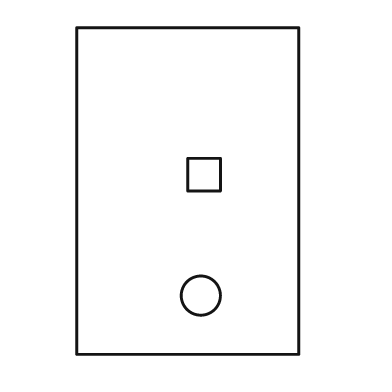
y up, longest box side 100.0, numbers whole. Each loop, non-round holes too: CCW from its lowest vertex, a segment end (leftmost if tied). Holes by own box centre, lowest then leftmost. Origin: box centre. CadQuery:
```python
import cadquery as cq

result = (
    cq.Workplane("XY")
    .moveTo(-34.0, -50.0)
    .lineTo(34.0, -50.0)
    .lineTo(34.0, 50.0)
    .lineTo(-34.0, 50.0)
    .close()
    .moveTo(4.0, -32.0)
    .circle(6.0)
    .moveTo(0.0, 0.0)
    .lineTo(10.0, 0.0)
    .lineTo(10.0, 10.0)
    .lineTo(0.0, 10.0)
    .close()
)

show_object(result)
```